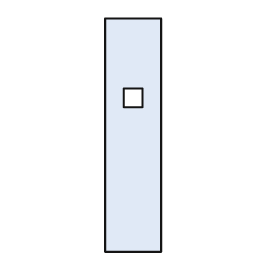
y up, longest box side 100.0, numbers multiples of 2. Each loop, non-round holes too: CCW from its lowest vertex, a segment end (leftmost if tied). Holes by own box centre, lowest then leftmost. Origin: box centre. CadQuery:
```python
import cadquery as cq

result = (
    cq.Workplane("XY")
    .moveTo(-12.0, -50.0)
    .lineTo(12.0, -50.0)
    .lineTo(12.0, 50.0)
    .lineTo(-12.0, 50.0)
    .close()
    .moveTo(-4.0, 12.0)
    .lineTo(4.0, 12.0)
    .lineTo(4.0, 20.0)
    .lineTo(-4.0, 20.0)
    .close()
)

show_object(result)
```